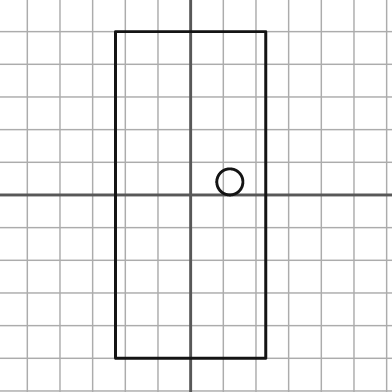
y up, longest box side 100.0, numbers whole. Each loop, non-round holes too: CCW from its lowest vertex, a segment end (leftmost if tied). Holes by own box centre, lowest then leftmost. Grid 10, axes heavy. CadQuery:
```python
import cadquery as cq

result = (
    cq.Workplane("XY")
    .moveTo(-23.0, -50.0)
    .lineTo(23.0, -50.0)
    .lineTo(23.0, 50.0)
    .lineTo(-23.0, 50.0)
    .close()
    .moveTo(12.0, 4.0)
    .circle(4.0)
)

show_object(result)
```